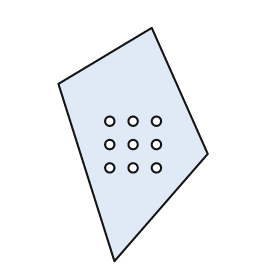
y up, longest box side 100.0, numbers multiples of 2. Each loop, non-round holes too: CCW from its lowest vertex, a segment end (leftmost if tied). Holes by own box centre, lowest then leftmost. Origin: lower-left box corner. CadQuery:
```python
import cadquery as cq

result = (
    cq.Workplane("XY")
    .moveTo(24.0, 0.0)
    .lineTo(64.0, 46.0)
    .lineTo(40.0, 100.0)
    .lineTo(0.0, 76.0)
    .close()
    .moveTo(22.0, 40.0)
    .circle(2.0)
    .moveTo(32.0, 40.0)
    .circle(2.0)
    .moveTo(42.0, 40.0)
    .circle(2.0)
    .moveTo(22.0, 50.0)
    .circle(2.0)
    .moveTo(32.0, 50.0)
    .circle(2.0)
    .moveTo(42.0, 50.0)
    .circle(2.0)
    .moveTo(22.0, 60.0)
    .circle(2.0)
    .moveTo(32.0, 60.0)
    .circle(2.0)
    .moveTo(42.0, 60.0)
    .circle(2.0)
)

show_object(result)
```